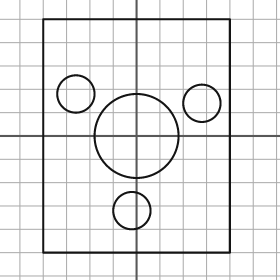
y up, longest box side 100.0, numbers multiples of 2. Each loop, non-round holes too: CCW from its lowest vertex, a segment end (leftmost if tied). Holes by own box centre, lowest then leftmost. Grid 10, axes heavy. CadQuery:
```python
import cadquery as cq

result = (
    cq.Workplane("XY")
    .moveTo(-40.0, -50.0)
    .lineTo(40.0, -50.0)
    .lineTo(40.0, 50.0)
    .lineTo(-40.0, 50.0)
    .close()
    .moveTo(-2.0, -32.0)
    .circle(8.0)
    .moveTo(0.0, 0.0)
    .circle(18.0)
    .moveTo(28.0, 14.0)
    .circle(8.0)
    .moveTo(-26.0, 18.0)
    .circle(8.0)
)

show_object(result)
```